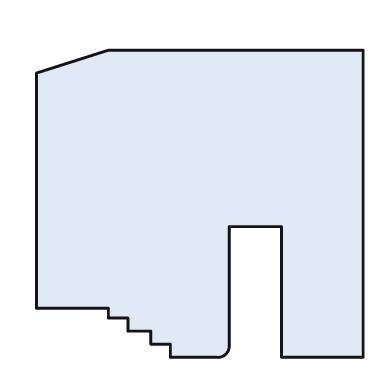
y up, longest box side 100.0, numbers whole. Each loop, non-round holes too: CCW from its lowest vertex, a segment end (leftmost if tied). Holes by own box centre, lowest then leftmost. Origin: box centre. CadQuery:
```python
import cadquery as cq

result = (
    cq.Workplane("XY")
    .moveTo(-9.0, -47.0)
    .lineTo(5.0, -47.0)
    .threePointArc((8.0, -46.0), (9.0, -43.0))
    .lineTo(9.0, -7.0)
    .lineTo(25.0, -7.0)
    .lineTo(25.0, -47.0)
    .lineTo(50.0, -47.0)
    .lineTo(50.0, 47.0)
    .lineTo(-28.0, 47.0)
    .lineTo(-50.0, 40.0)
    .lineTo(-50.0, -32.0)
    .lineTo(-28.0, -32.0)
    .lineTo(-28.0, -35.0)
    .lineTo(-22.0, -35.0)
    .lineTo(-22.0, -39.0)
    .lineTo(-15.0, -39.0)
    .lineTo(-15.0, -43.0)
    .lineTo(-9.0, -43.0)
    .close()
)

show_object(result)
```